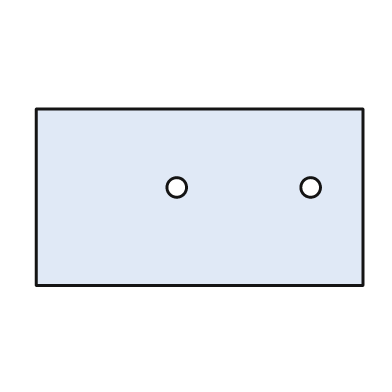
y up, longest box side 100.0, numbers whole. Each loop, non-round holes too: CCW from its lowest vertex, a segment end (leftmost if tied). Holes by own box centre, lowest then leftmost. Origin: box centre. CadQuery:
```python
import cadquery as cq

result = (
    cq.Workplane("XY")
    .moveTo(-50.0, -27.0)
    .lineTo(50.0, -27.0)
    .lineTo(50.0, 27.0)
    .lineTo(-50.0, 27.0)
    .close()
    .moveTo(-7.0, 3.0)
    .circle(3.0)
    .moveTo(34.0, 3.0)
    .circle(3.0)
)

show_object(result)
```